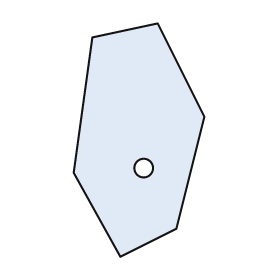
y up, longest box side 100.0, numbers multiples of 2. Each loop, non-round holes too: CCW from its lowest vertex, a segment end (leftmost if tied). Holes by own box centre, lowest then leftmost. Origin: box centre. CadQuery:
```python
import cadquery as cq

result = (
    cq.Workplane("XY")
    .moveTo(-8.0, -50.0)
    .lineTo(16.0, -38.0)
    .lineTo(28.0, 10.0)
    .lineTo(8.0, 50.0)
    .lineTo(-20.0, 44.0)
    .lineTo(-28.0, -14.0)
    .close()
    .moveTo(2.0, -12.0)
    .circle(4.0)
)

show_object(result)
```